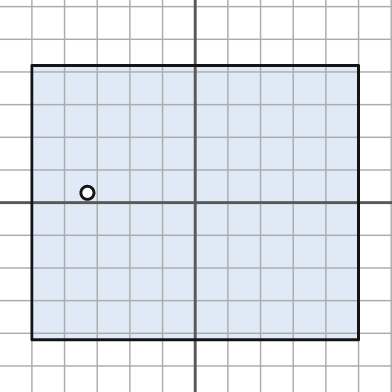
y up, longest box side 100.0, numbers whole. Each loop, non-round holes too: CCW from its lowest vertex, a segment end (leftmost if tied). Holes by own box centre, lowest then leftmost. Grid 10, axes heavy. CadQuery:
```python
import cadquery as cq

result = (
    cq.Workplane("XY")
    .moveTo(-50.0, -42.0)
    .lineTo(50.0, -42.0)
    .lineTo(50.0, 42.0)
    .lineTo(-50.0, 42.0)
    .close()
    .moveTo(-33.0, 3.0)
    .circle(2.0)
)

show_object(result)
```